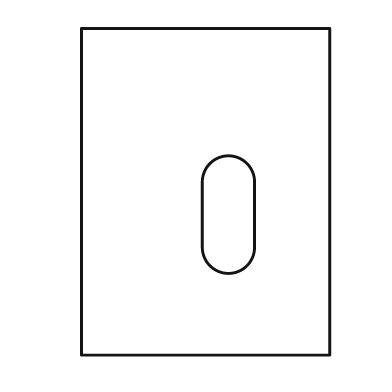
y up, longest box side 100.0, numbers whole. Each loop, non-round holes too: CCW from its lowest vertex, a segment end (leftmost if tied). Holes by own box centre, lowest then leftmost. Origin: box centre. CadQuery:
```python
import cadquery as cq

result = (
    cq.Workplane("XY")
    .moveTo(-38.0, -50.0)
    .lineTo(38.0, -50.0)
    .lineTo(38.0, 50.0)
    .lineTo(-38.0, 50.0)
    .close()
    .moveTo(-1.0, -17.0)
    .threePointArc((7.0, -25.0), (15.0, -17.0))
    .lineTo(15.0, 3.0)
    .threePointArc((7.0, 11.0), (-1.0, 3.0))
    .close()
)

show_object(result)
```